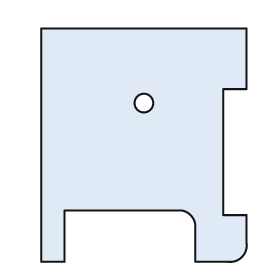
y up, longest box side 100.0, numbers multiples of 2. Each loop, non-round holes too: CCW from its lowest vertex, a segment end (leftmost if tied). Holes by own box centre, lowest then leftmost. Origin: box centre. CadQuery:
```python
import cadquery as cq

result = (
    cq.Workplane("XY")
    .moveTo(-44.0, -50.0)
    .lineTo(-34.0, -50.0)
    .lineTo(-34.0, -28.0)
    .lineTo(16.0, -28.0)
    .threePointArc((20.0, -30.0), (22.0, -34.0))
    .lineTo(22.0, -50.0)
    .lineTo(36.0, -50.0)
    .threePointArc((42.0, -48.0), (44.0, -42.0))
    .lineTo(44.0, -30.0)
    .lineTo(34.0, -30.0)
    .lineTo(34.0, 24.0)
    .lineTo(44.0, 24.0)
    .lineTo(44.0, 50.0)
    .lineTo(-44.0, 50.0)
    .close()
    .moveTo(0.0, 18.0)
    .circle(4.0)
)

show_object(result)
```